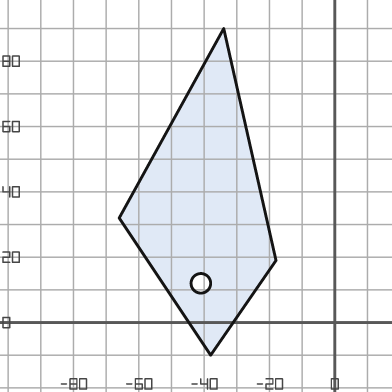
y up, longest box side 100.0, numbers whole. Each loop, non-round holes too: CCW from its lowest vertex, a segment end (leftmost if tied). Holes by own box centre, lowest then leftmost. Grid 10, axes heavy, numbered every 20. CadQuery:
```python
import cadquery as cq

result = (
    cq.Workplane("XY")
    .moveTo(-38.0, -10.0)
    .lineTo(-18.0, 19.0)
    .lineTo(-34.0, 90.0)
    .lineTo(-66.0, 32.0)
    .close()
    .moveTo(-41.0, 12.0)
    .circle(3.0)
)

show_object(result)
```